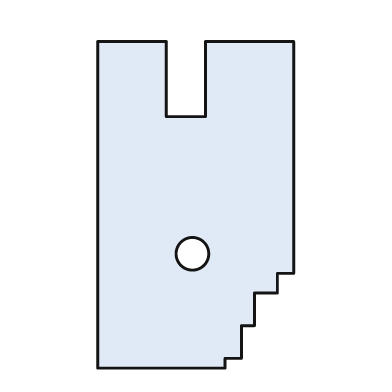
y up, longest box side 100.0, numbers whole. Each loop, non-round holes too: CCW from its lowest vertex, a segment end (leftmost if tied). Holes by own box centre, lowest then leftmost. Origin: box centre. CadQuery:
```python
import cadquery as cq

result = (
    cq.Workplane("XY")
    .moveTo(-30.0, -50.0)
    .lineTo(9.0, -50.0)
    .lineTo(9.0, -47.0)
    .lineTo(14.0, -47.0)
    .lineTo(14.0, -37.0)
    .lineTo(18.0, -37.0)
    .lineTo(18.0, -27.0)
    .lineTo(25.0, -27.0)
    .lineTo(25.0, -21.0)
    .lineTo(30.0, -21.0)
    .lineTo(30.0, 50.0)
    .lineTo(3.0, 50.0)
    .lineTo(3.0, 27.0)
    .lineTo(-9.0, 27.0)
    .lineTo(-9.0, 50.0)
    .lineTo(-30.0, 50.0)
    .close()
    .moveTo(-1.0, -15.0)
    .circle(5.0)
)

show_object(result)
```